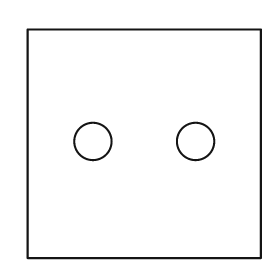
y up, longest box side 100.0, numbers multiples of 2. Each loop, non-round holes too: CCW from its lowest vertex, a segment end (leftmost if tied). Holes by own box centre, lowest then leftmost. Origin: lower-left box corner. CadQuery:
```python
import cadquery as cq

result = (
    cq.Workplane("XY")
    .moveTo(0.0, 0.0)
    .lineTo(100.0, 0.0)
    .lineTo(100.0, 98.0)
    .lineTo(0.0, 98.0)
    .close()
    .moveTo(28.0, 50.0)
    .circle(8.0)
    .moveTo(72.0, 50.0)
    .circle(8.0)
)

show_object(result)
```